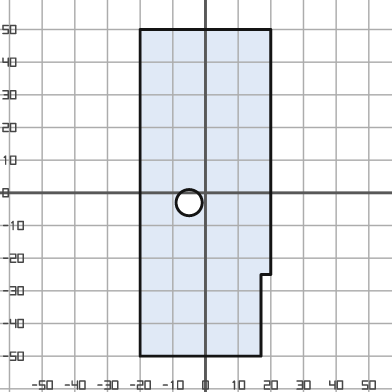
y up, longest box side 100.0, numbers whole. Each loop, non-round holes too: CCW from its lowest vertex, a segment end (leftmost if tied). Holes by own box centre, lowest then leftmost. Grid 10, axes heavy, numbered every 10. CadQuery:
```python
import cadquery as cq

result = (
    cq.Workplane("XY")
    .moveTo(-20.0, -50.0)
    .lineTo(17.0, -50.0)
    .lineTo(17.0, -25.0)
    .lineTo(20.0, -25.0)
    .lineTo(20.0, 50.0)
    .lineTo(-20.0, 50.0)
    .close()
    .moveTo(-5.0, -3.0)
    .circle(4.0)
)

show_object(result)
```